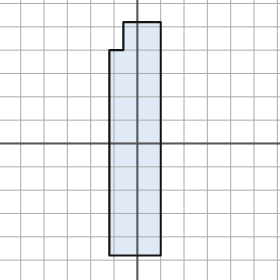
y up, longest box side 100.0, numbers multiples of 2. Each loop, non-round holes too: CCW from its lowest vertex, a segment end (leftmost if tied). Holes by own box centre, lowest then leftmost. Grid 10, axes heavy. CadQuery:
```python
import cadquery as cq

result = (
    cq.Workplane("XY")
    .moveTo(-12.0, -48.0)
    .lineTo(10.0, -48.0)
    .lineTo(10.0, 52.0)
    .lineTo(-6.0, 52.0)
    .lineTo(-6.0, 40.0)
    .lineTo(-12.0, 40.0)
    .close()
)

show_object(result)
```